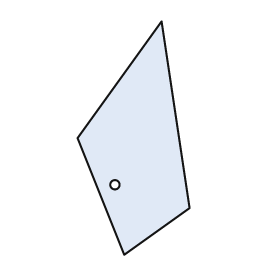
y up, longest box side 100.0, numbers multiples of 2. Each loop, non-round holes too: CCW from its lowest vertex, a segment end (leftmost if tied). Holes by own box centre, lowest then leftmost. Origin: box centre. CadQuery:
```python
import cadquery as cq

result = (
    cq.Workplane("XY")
    .moveTo(-4.0, -50.0)
    .lineTo(24.0, -30.0)
    .lineTo(12.0, 50.0)
    .lineTo(-24.0, 0.0)
    .close()
    .moveTo(-8.0, -20.0)
    .circle(2.0)
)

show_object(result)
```